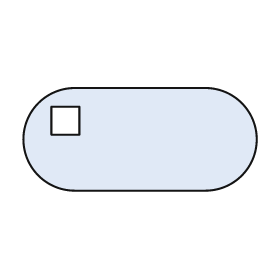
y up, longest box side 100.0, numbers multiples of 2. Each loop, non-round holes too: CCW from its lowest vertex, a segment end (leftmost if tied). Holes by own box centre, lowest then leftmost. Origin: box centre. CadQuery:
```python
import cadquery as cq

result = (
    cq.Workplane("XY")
    .moveTo(-28.0, -22.0)
    .lineTo(28.0, -22.0)
    .threePointArc((50.0, 0.0), (28.0, 22.0))
    .lineTo(-28.0, 22.0)
    .threePointArc((-50.0, 0.0), (-28.0, -22.0))
    .close()
    .moveTo(-38.0, 2.0)
    .lineTo(-26.0, 2.0)
    .lineTo(-26.0, 14.0)
    .lineTo(-38.0, 14.0)
    .close()
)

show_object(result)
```